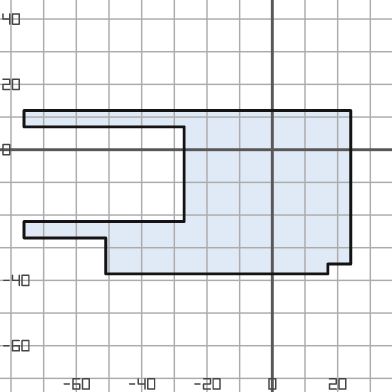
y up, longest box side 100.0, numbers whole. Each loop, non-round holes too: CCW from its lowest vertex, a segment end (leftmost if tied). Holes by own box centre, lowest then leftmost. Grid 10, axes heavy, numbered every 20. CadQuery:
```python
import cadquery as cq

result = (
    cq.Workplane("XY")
    .moveTo(-51.0, -38.0)
    .lineTo(17.0, -38.0)
    .lineTo(17.0, -35.0)
    .lineTo(24.0, -35.0)
    .lineTo(24.0, 12.0)
    .lineTo(-76.0, 12.0)
    .lineTo(-76.0, 7.0)
    .lineTo(-27.0, 7.0)
    .lineTo(-27.0, -22.0)
    .lineTo(-76.0, -22.0)
    .lineTo(-76.0, -27.0)
    .lineTo(-51.0, -27.0)
    .close()
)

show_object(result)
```